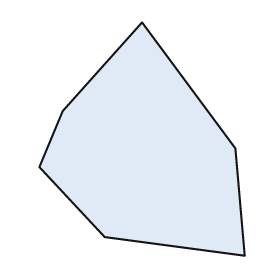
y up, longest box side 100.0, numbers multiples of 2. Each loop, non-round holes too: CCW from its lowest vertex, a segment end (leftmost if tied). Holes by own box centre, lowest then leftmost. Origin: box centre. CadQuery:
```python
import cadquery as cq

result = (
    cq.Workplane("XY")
    .moveTo(44.0, -50.0)
    .lineTo(40.0, -4.0)
    .lineTo(0.0, 50.0)
    .lineTo(-34.0, 12.0)
    .lineTo(-44.0, -12.0)
    .lineTo(-16.0, -42.0)
    .close()
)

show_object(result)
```